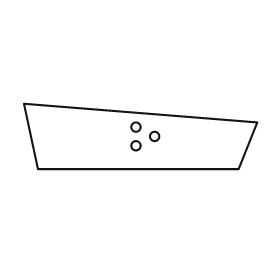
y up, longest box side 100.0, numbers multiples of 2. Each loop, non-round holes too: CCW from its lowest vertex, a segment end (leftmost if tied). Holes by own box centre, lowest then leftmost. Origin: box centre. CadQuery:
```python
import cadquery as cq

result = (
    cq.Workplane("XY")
    .moveTo(-44.0, -14.0)
    .lineTo(42.0, -14.0)
    .lineTo(50.0, 6.0)
    .lineTo(-50.0, 14.0)
    .close()
    .moveTo(-2.0, -4.0)
    .circle(2.0)
    .moveTo(6.0, 0.0)
    .circle(2.0)
    .moveTo(-2.0, 4.0)
    .circle(2.0)
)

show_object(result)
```